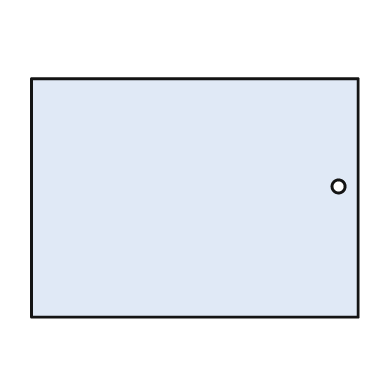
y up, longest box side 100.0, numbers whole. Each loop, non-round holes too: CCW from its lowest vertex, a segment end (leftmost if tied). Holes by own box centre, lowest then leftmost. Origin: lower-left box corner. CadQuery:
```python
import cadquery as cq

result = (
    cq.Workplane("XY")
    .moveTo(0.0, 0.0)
    .lineTo(100.0, 0.0)
    .lineTo(100.0, 73.0)
    .lineTo(0.0, 73.0)
    .close()
    .moveTo(94.0, 40.0)
    .circle(2.0)
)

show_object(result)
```